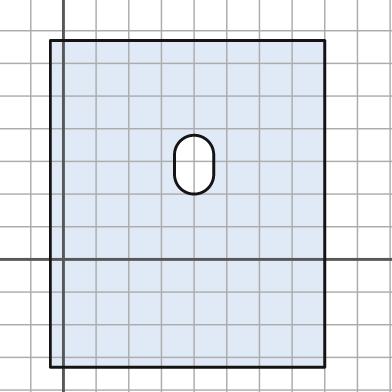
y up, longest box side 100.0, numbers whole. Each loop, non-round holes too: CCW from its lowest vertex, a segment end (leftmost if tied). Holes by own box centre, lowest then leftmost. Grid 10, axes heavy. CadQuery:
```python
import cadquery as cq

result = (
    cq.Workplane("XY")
    .moveTo(-4.0, -33.0)
    .lineTo(80.0, -33.0)
    .lineTo(80.0, 67.0)
    .lineTo(-4.0, 67.0)
    .close()
    .moveTo(34.0, 26.0)
    .threePointArc((40.0, 20.0), (46.0, 26.0))
    .lineTo(46.0, 32.0)
    .threePointArc((40.0, 38.0), (34.0, 32.0))
    .close()
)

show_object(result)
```